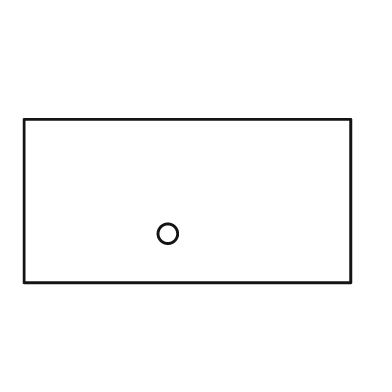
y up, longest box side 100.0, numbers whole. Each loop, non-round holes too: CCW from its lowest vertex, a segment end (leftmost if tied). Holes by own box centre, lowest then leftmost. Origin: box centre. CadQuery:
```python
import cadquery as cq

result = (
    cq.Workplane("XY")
    .moveTo(-50.0, -25.0)
    .lineTo(50.0, -25.0)
    .lineTo(50.0, 25.0)
    .lineTo(-50.0, 25.0)
    .close()
    .moveTo(-6.0, -10.0)
    .circle(3.0)
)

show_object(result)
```